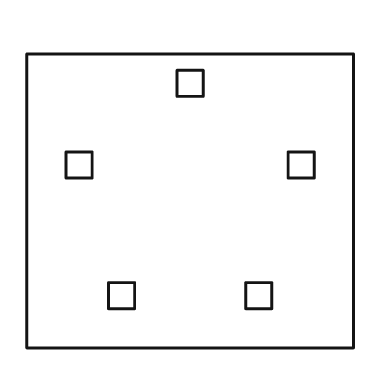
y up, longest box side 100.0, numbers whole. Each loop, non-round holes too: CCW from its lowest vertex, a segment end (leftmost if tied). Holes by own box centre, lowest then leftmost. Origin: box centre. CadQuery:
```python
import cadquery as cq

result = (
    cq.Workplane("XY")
    .moveTo(-50.0, -45.0)
    .lineTo(50.0, -45.0)
    .lineTo(50.0, 45.0)
    .lineTo(-50.0, 45.0)
    .close()
    .moveTo(-25.0, -33.0)
    .lineTo(-17.0, -33.0)
    .lineTo(-17.0, -25.0)
    .lineTo(-25.0, -25.0)
    .close()
    .moveTo(17.0, -33.0)
    .lineTo(25.0, -33.0)
    .lineTo(25.0, -25.0)
    .lineTo(17.0, -25.0)
    .close()
    .moveTo(-38.0, 7.0)
    .lineTo(-30.0, 7.0)
    .lineTo(-30.0, 15.0)
    .lineTo(-38.0, 15.0)
    .close()
    .moveTo(30.0, 7.0)
    .lineTo(38.0, 7.0)
    .lineTo(38.0, 15.0)
    .lineTo(30.0, 15.0)
    .close()
    .moveTo(-4.0, 32.0)
    .lineTo(4.0, 32.0)
    .lineTo(4.0, 40.0)
    .lineTo(-4.0, 40.0)
    .close()
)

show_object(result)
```